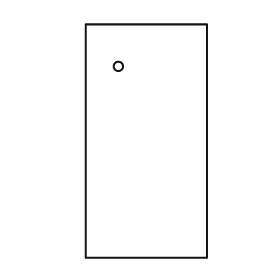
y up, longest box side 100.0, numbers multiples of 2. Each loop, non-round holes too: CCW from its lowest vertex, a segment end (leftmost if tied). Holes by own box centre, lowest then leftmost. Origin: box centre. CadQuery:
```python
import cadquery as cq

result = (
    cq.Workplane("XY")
    .moveTo(-26.0, -50.0)
    .lineTo(26.0, -50.0)
    .lineTo(26.0, 50.0)
    .lineTo(-26.0, 50.0)
    .close()
    .moveTo(-12.0, 32.0)
    .circle(2.0)
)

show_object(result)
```